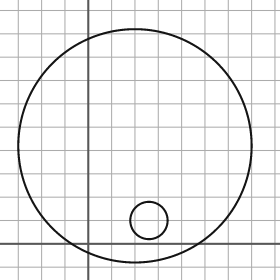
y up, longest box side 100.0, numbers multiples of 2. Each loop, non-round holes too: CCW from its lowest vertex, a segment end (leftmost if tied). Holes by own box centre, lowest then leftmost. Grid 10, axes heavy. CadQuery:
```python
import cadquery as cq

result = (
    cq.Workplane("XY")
    .moveTo(20.0, 42.0)
    .circle(50.0)
    .moveTo(26.0, 10.0)
    .circle(8.0)
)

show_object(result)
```